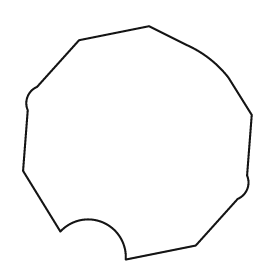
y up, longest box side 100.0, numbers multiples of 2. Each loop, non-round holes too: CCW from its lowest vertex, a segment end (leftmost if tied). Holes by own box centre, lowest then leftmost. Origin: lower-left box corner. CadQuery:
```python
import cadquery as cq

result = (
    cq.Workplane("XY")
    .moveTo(44.0, 0.0)
    .lineTo(74.0, 6.0)
    .lineTo(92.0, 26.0)
    .threePointArc((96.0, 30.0), (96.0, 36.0))
    .lineTo(98.0, 62.0)
    .lineTo(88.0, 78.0)
    .threePointArc((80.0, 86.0), (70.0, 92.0))
    .lineTo(54.0, 100.0)
    .lineTo(24.0, 94.0)
    .lineTo(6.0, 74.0)
    .threePointArc((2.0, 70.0), (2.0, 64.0))
    .lineTo(0.0, 38.0)
    .lineTo(16.0, 12.0)
    .threePointArc((34.0, 16.0), (44.0, 0.0))
    .close()
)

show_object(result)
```